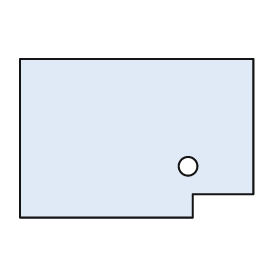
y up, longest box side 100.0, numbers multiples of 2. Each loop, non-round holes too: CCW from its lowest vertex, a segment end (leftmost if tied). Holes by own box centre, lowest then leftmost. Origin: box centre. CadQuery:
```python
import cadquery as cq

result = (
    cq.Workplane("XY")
    .moveTo(-50.0, -34.0)
    .lineTo(24.0, -34.0)
    .lineTo(24.0, -24.0)
    .lineTo(50.0, -24.0)
    .lineTo(50.0, 34.0)
    .lineTo(-50.0, 34.0)
    .close()
    .moveTo(22.0, -12.0)
    .circle(4.0)
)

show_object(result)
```